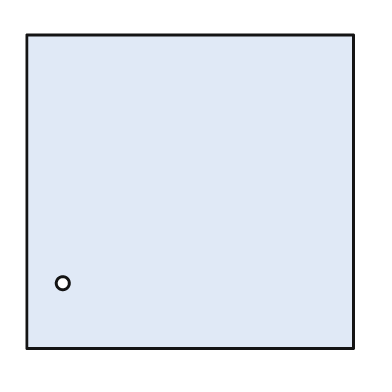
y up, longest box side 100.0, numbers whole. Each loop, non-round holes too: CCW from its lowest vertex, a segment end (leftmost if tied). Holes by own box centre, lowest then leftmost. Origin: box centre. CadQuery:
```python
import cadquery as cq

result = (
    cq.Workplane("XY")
    .moveTo(-50.0, -48.0)
    .lineTo(50.0, -48.0)
    .lineTo(50.0, 48.0)
    .lineTo(-50.0, 48.0)
    .close()
    .moveTo(-39.0, -28.0)
    .circle(2.0)
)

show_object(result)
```